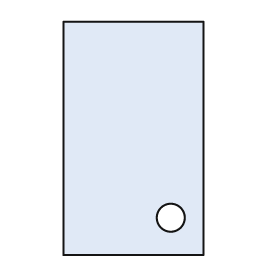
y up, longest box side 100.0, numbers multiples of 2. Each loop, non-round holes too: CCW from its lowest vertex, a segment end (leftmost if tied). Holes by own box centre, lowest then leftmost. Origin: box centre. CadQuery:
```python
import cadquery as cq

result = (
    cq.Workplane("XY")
    .moveTo(-30.0, -50.0)
    .lineTo(30.0, -50.0)
    .lineTo(30.0, 50.0)
    .lineTo(-30.0, 50.0)
    .close()
    .moveTo(16.0, -34.0)
    .circle(6.0)
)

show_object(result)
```